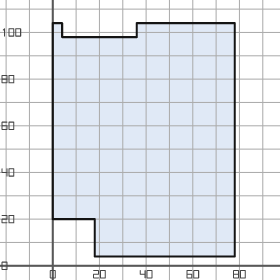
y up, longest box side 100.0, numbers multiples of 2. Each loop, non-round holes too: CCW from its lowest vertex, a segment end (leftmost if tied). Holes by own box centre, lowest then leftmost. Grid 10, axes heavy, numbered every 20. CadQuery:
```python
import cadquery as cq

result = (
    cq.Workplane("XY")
    .moveTo(18.0, 4.0)
    .lineTo(78.0, 4.0)
    .lineTo(78.0, 104.0)
    .lineTo(36.0, 104.0)
    .lineTo(36.0, 98.0)
    .lineTo(4.0, 98.0)
    .lineTo(4.0, 104.0)
    .lineTo(0.0, 104.0)
    .lineTo(0.0, 20.0)
    .lineTo(18.0, 20.0)
    .close()
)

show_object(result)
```